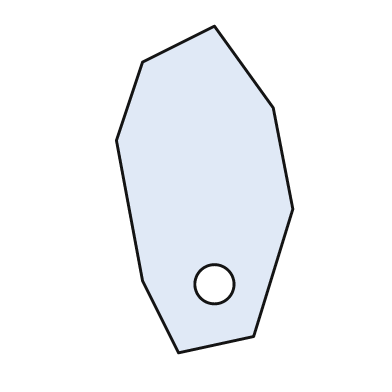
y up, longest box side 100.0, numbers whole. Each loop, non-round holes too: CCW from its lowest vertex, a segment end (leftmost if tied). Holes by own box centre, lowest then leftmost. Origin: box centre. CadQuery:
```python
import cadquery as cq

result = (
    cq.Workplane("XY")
    .moveTo(-8.0, -50.0)
    .lineTo(15.0, -45.0)
    .lineTo(27.0, -6.0)
    .lineTo(21.0, 25.0)
    .lineTo(3.0, 50.0)
    .lineTo(-19.0, 39.0)
    .lineTo(-27.0, 15.0)
    .lineTo(-19.0, -28.0)
    .close()
    .moveTo(3.0, -29.0)
    .circle(6.0)
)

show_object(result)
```